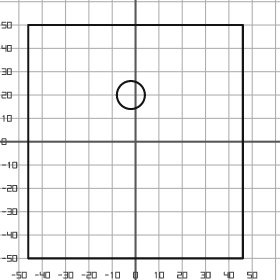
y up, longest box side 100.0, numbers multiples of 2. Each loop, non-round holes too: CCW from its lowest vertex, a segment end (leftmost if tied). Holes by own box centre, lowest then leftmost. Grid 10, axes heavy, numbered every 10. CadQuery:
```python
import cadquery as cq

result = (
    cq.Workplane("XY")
    .moveTo(-46.0, -50.0)
    .lineTo(46.0, -50.0)
    .lineTo(46.0, 50.0)
    .lineTo(-46.0, 50.0)
    .close()
    .moveTo(-2.0, 20.0)
    .circle(6.0)
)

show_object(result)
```